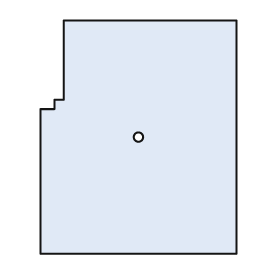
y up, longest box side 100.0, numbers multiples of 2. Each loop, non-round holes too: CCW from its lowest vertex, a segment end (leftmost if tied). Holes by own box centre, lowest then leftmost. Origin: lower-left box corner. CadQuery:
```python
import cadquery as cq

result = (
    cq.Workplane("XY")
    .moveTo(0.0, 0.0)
    .lineTo(84.0, 0.0)
    .lineTo(84.0, 100.0)
    .lineTo(10.0, 100.0)
    .lineTo(10.0, 66.0)
    .lineTo(6.0, 66.0)
    .lineTo(6.0, 62.0)
    .lineTo(0.0, 62.0)
    .close()
    .moveTo(42.0, 50.0)
    .circle(2.0)
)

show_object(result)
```